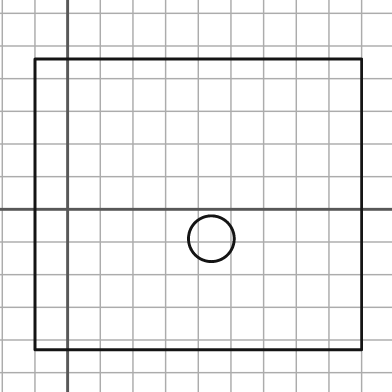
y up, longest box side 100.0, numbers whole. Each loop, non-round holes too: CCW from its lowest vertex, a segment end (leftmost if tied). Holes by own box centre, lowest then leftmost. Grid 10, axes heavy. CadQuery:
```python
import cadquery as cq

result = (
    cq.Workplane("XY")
    .moveTo(-10.0, -43.0)
    .lineTo(90.0, -43.0)
    .lineTo(90.0, 46.0)
    .lineTo(-10.0, 46.0)
    .close()
    .moveTo(44.0, -9.0)
    .circle(7.0)
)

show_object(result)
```